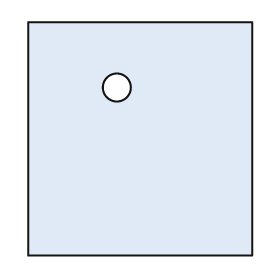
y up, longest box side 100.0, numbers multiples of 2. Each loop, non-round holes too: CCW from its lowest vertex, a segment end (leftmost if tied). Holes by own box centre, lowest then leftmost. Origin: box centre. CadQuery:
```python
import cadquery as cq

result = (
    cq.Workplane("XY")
    .moveTo(-48.0, -50.0)
    .lineTo(48.0, -50.0)
    .lineTo(48.0, 50.0)
    .lineTo(-48.0, 50.0)
    .close()
    .moveTo(-10.0, 22.0)
    .circle(6.0)
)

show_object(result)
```